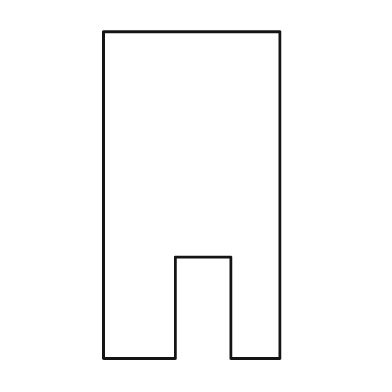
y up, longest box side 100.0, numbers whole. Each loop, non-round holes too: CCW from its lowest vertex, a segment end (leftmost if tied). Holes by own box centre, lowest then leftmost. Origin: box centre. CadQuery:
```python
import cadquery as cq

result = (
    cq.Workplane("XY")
    .moveTo(-27.0, -50.0)
    .lineTo(-5.0, -50.0)
    .lineTo(-5.0, -19.0)
    .lineTo(12.0, -19.0)
    .lineTo(12.0, -50.0)
    .lineTo(27.0, -50.0)
    .lineTo(27.0, 50.0)
    .lineTo(-27.0, 50.0)
    .close()
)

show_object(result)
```